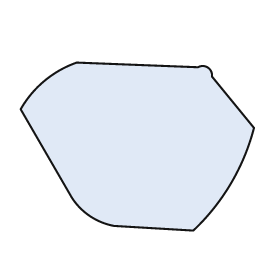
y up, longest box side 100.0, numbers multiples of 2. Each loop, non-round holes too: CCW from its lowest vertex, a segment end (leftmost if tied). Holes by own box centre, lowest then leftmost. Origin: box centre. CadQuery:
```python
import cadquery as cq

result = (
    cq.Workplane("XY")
    .moveTo(24.0, -36.0)
    .threePointArc((40.0, -16.0), (50.0, 8.0))
    .lineTo(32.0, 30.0)
    .threePointArc((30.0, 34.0), (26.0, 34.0))
    .lineTo(-26.0, 36.0)
    .threePointArc((-40.0, 28.0), (-50.0, 16.0))
    .lineTo(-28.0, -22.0)
    .threePointArc((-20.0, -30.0), (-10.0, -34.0))
    .close()
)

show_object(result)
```